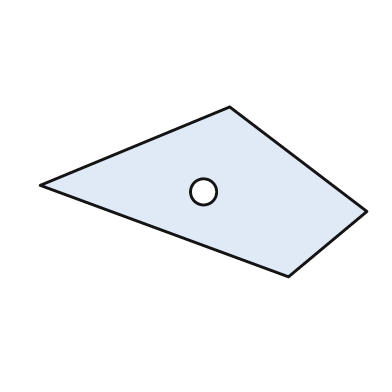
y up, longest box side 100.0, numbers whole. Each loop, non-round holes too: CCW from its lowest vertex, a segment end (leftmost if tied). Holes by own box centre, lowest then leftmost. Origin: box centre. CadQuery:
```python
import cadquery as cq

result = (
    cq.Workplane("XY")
    .moveTo(26.0, -26.0)
    .lineTo(50.0, -6.0)
    .lineTo(8.0, 26.0)
    .lineTo(-50.0, 2.0)
    .close()
    .moveTo(0.0, 0.0)
    .circle(4.0)
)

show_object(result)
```